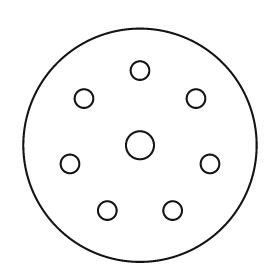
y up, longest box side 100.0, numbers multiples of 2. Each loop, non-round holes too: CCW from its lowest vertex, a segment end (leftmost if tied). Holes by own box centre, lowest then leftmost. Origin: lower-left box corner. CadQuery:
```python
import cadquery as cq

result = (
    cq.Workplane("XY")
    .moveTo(50.0, 50.0)
    .circle(50.0)
    .moveTo(36.0, 22.0)
    .circle(4.0)
    .moveTo(64.0, 22.0)
    .circle(4.0)
    .moveTo(20.0, 42.0)
    .circle(4.0)
    .moveTo(80.0, 42.0)
    .circle(4.0)
    .moveTo(50.0, 50.0)
    .circle(6.0)
    .moveTo(26.0, 70.0)
    .circle(4.0)
    .moveTo(74.0, 70.0)
    .circle(4.0)
    .moveTo(50.0, 82.0)
    .circle(4.0)
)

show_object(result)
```